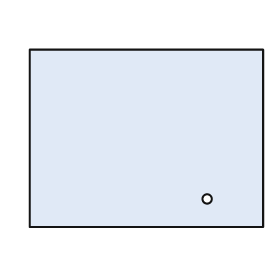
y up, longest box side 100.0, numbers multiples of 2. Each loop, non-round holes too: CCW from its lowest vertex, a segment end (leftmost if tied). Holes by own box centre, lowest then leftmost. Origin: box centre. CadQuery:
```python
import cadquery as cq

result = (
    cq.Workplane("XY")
    .moveTo(-50.0, -38.0)
    .lineTo(50.0, -38.0)
    .lineTo(50.0, 38.0)
    .lineTo(-50.0, 38.0)
    .close()
    .moveTo(26.0, -26.0)
    .circle(2.0)
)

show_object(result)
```